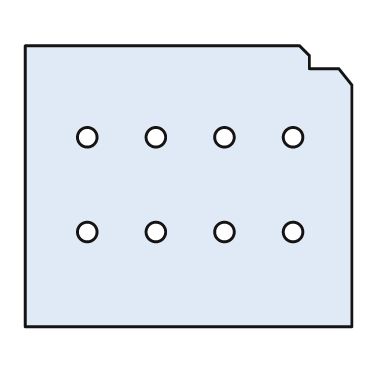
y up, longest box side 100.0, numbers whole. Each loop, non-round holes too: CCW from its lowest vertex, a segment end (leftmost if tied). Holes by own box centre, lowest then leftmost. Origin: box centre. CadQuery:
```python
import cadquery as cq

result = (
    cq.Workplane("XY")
    .moveTo(-50.0, -43.0)
    .lineTo(50.0, -43.0)
    .lineTo(50.0, 31.0)
    .lineTo(46.0, 36.0)
    .lineTo(37.0, 36.0)
    .lineTo(37.0, 40.0)
    .lineTo(34.0, 43.0)
    .lineTo(-50.0, 43.0)
    .close()
    .moveTo(-31.0, -14.0)
    .circle(3.0)
    .moveTo(-10.0, -14.0)
    .circle(3.0)
    .moveTo(11.0, -14.0)
    .circle(3.0)
    .moveTo(32.0, -14.0)
    .circle(3.0)
    .moveTo(-31.0, 15.0)
    .circle(3.0)
    .moveTo(-10.0, 15.0)
    .circle(3.0)
    .moveTo(11.0, 15.0)
    .circle(3.0)
    .moveTo(32.0, 15.0)
    .circle(3.0)
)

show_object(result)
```